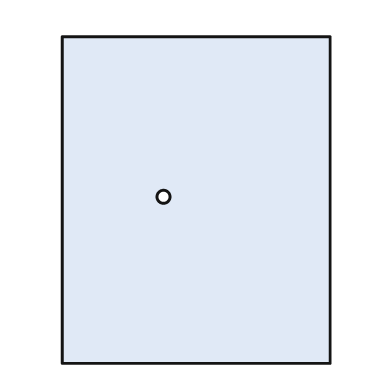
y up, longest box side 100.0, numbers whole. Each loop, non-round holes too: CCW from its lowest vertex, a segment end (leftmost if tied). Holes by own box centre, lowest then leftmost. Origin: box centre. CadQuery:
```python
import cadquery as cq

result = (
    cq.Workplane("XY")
    .moveTo(-41.0, -50.0)
    .lineTo(41.0, -50.0)
    .lineTo(41.0, 50.0)
    .lineTo(-41.0, 50.0)
    .close()
    .moveTo(-10.0, 1.0)
    .circle(2.0)
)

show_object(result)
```